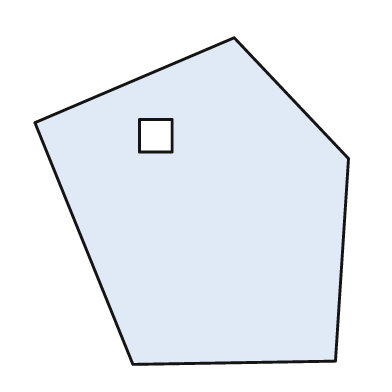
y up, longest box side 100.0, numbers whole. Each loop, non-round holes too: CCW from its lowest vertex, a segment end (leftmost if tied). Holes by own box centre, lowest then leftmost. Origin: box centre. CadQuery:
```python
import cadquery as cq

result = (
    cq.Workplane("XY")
    .moveTo(-18.0, -50.0)
    .lineTo(44.0, -49.0)
    .lineTo(48.0, 13.0)
    .lineTo(13.0, 50.0)
    .lineTo(-48.0, 24.0)
    .close()
    .moveTo(-16.0, 15.0)
    .lineTo(-6.0, 15.0)
    .lineTo(-6.0, 25.0)
    .lineTo(-16.0, 25.0)
    .close()
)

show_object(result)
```